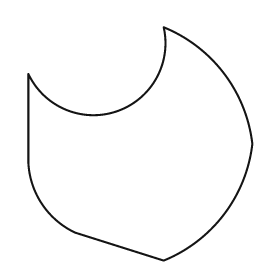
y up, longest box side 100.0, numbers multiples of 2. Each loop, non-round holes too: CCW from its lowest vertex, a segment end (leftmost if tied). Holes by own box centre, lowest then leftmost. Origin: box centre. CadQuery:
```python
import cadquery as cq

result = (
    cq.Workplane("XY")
    .moveTo(10.0, -50.0)
    .threePointArc((36.0, -30.0), (48.0, 0.0))
    .threePointArc((36.0, 30.0), (10.0, 50.0))
    .threePointArc((-10.0, 14.0), (-48.0, 30.0))
    .lineTo(-48.0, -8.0)
    .threePointArc((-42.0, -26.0), (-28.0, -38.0))
    .close()
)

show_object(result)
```